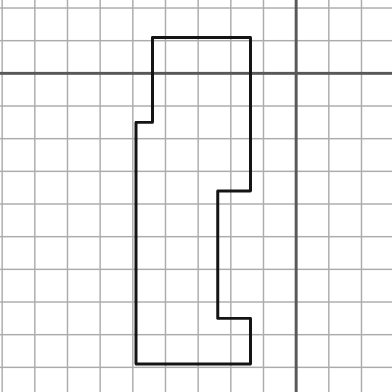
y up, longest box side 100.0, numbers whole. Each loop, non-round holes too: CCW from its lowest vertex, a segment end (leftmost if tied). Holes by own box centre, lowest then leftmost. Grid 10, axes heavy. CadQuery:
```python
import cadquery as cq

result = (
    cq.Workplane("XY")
    .moveTo(-49.0, -89.0)
    .lineTo(-14.0, -89.0)
    .lineTo(-14.0, -75.0)
    .lineTo(-24.0, -75.0)
    .lineTo(-24.0, -36.0)
    .lineTo(-14.0, -36.0)
    .lineTo(-14.0, 11.0)
    .lineTo(-44.0, 11.0)
    .lineTo(-44.0, -15.0)
    .lineTo(-49.0, -15.0)
    .close()
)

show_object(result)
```